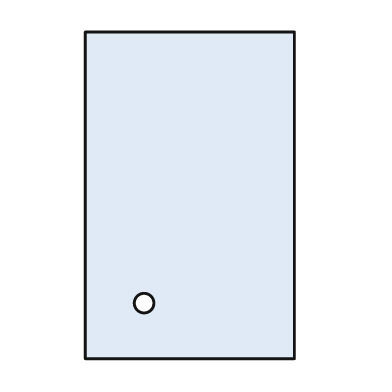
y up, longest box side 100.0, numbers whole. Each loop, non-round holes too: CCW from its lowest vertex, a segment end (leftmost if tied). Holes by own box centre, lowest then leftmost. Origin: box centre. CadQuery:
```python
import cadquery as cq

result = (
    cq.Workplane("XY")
    .moveTo(-32.0, -50.0)
    .lineTo(32.0, -50.0)
    .lineTo(32.0, 50.0)
    .lineTo(-32.0, 50.0)
    .close()
    .moveTo(-14.0, -33.0)
    .circle(3.0)
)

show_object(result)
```